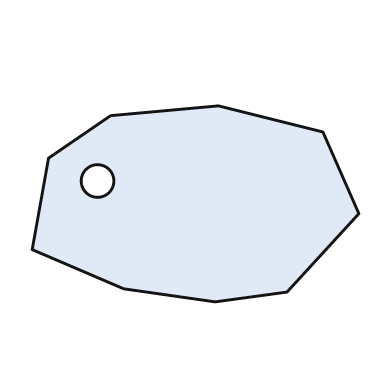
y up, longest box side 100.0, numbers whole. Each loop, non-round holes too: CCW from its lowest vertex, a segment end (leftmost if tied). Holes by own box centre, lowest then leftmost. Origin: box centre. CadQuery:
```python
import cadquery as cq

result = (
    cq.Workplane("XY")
    .moveTo(6.0, -30.0)
    .lineTo(28.0, -27.0)
    .lineTo(50.0, -3.0)
    .lineTo(39.0, 22.0)
    .lineTo(7.0, 30.0)
    .lineTo(-26.0, 27.0)
    .lineTo(-45.0, 14.0)
    .lineTo(-50.0, -14.0)
    .lineTo(-22.0, -26.0)
    .close()
    .moveTo(-30.0, 7.0)
    .circle(5.0)
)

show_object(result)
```